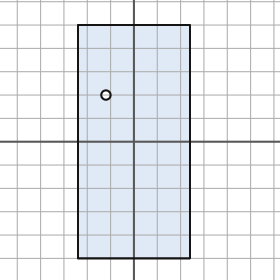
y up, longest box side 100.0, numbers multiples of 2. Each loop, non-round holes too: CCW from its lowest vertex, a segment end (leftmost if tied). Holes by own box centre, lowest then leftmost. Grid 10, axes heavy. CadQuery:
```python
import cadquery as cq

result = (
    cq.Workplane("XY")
    .moveTo(-24.0, -50.0)
    .lineTo(24.0, -50.0)
    .lineTo(24.0, 50.0)
    .lineTo(-24.0, 50.0)
    .close()
    .moveTo(-12.0, 20.0)
    .circle(2.0)
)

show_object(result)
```